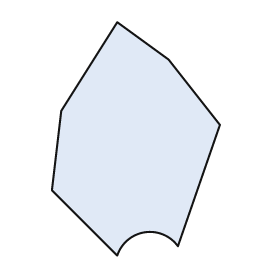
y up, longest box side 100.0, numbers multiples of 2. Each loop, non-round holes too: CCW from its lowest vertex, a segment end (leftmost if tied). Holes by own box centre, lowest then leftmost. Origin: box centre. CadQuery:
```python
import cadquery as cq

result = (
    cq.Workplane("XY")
    .moveTo(-8.0, -50.0)
    .threePointArc((4.0, -40.0), (18.0, -46.0))
    .lineTo(36.0, 6.0)
    .lineTo(14.0, 34.0)
    .lineTo(-8.0, 50.0)
    .lineTo(-32.0, 12.0)
    .lineTo(-36.0, -22.0)
    .close()
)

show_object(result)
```